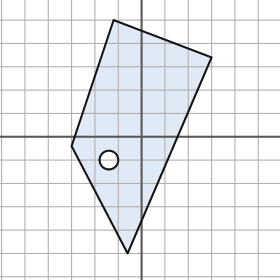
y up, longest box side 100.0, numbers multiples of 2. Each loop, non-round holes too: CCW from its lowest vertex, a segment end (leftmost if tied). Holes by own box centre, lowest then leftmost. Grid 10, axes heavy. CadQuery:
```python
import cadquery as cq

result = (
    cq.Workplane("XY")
    .moveTo(-6.0, -50.0)
    .lineTo(30.0, 34.0)
    .lineTo(-12.0, 50.0)
    .lineTo(-30.0, -4.0)
    .close()
    .moveTo(-14.0, -10.0)
    .circle(4.0)
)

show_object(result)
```